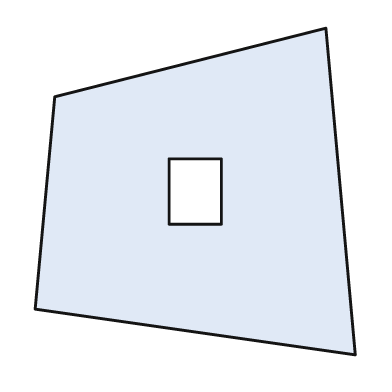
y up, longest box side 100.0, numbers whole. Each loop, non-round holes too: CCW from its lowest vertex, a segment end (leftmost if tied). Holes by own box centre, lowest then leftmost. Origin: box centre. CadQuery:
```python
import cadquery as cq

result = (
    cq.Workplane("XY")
    .moveTo(49.0, -50.0)
    .lineTo(40.0, 50.0)
    .lineTo(-43.0, 29.0)
    .lineTo(-49.0, -36.0)
    .close()
    .moveTo(-8.0, -10.0)
    .lineTo(8.0, -10.0)
    .lineTo(8.0, 10.0)
    .lineTo(-8.0, 10.0)
    .close()
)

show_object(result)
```